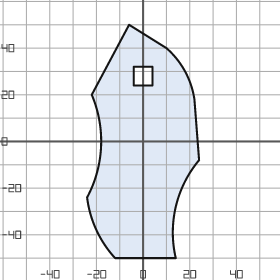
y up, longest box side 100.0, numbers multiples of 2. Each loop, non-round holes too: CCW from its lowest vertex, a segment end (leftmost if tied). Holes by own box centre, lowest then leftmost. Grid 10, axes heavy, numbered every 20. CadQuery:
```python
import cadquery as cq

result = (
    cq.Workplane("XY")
    .moveTo(-12.0, -50.0)
    .lineTo(14.0, -50.0)
    .threePointArc((14.0, -28.0), (24.0, -8.0))
    .lineTo(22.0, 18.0)
    .threePointArc((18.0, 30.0), (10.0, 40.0))
    .lineTo(-6.0, 50.0)
    .lineTo(-22.0, 20.0)
    .threePointArc((-18.0, -2.0), (-24.0, -24.0))
    .threePointArc((-20.0, -38.0), (-12.0, -50.0))
    .close()
    .moveTo(-4.0, 24.0)
    .lineTo(4.0, 24.0)
    .lineTo(4.0, 32.0)
    .lineTo(-4.0, 32.0)
    .close()
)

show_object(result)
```